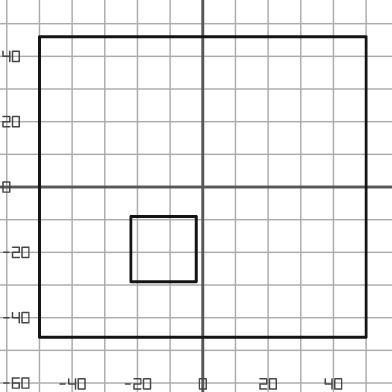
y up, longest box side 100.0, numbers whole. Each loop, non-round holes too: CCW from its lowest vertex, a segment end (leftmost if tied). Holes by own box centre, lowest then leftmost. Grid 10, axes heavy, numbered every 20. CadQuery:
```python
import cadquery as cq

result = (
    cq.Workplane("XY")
    .moveTo(-50.0, -46.0)
    .lineTo(50.0, -46.0)
    .lineTo(50.0, 46.0)
    .lineTo(-50.0, 46.0)
    .close()
    .moveTo(-22.0, -29.0)
    .lineTo(-2.0, -29.0)
    .lineTo(-2.0, -9.0)
    .lineTo(-22.0, -9.0)
    .close()
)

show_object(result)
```